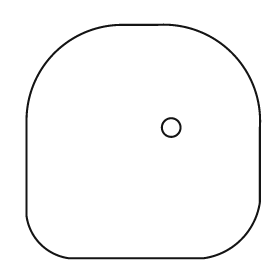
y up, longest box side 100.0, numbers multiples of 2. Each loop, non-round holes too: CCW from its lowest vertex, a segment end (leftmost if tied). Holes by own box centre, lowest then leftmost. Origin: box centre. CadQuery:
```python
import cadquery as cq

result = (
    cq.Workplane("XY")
    .moveTo(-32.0, -50.0)
    .lineTo(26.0, -50.0)
    .threePointArc((42.0, -42.0), (50.0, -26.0))
    .lineTo(50.0, 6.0)
    .threePointArc((38.0, 38.0), (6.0, 50.0))
    .lineTo(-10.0, 50.0)
    .threePointArc((-38.0, 38.0), (-50.0, 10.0))
    .lineTo(-50.0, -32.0)
    .threePointArc((-44.0, -44.0), (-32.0, -50.0))
    .close()
    .moveTo(12.0, 6.0)
    .circle(4.0)
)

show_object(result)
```